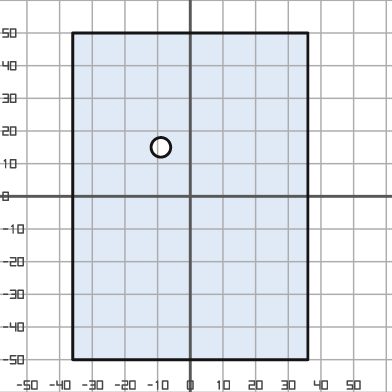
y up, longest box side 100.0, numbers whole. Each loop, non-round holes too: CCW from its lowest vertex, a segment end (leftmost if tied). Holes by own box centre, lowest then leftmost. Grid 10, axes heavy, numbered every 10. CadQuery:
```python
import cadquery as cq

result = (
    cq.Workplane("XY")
    .moveTo(-36.0, -50.0)
    .lineTo(36.0, -50.0)
    .lineTo(36.0, 50.0)
    .lineTo(-36.0, 50.0)
    .close()
    .moveTo(-9.0, 15.0)
    .circle(3.0)
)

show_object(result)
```